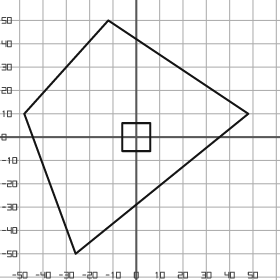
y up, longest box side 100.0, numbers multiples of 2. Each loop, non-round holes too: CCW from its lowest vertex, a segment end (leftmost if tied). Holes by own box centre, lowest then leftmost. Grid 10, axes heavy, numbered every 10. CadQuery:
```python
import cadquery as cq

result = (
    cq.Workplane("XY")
    .moveTo(-26.0, -50.0)
    .lineTo(48.0, 10.0)
    .lineTo(-12.0, 50.0)
    .lineTo(-48.0, 10.0)
    .close()
    .moveTo(-6.0, -6.0)
    .lineTo(6.0, -6.0)
    .lineTo(6.0, 6.0)
    .lineTo(-6.0, 6.0)
    .close()
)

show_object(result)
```